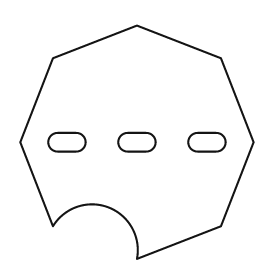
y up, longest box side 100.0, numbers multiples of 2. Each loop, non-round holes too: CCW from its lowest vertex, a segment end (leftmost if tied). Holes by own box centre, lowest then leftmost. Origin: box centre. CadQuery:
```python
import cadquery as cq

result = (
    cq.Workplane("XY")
    .moveTo(0.0, -50.0)
    .lineTo(36.0, -36.0)
    .lineTo(50.0, 0.0)
    .lineTo(36.0, 36.0)
    .lineTo(0.0, 50.0)
    .lineTo(-36.0, 36.0)
    .lineTo(-50.0, 0.0)
    .lineTo(-36.0, -36.0)
    .threePointArc((-12.0, -28.0), (0.0, -50.0))
    .close()
    .moveTo(-34.0, -4.0)
    .lineTo(-26.0, -4.0)
    .threePointArc((-22.0, 0.0), (-26.0, 4.0))
    .lineTo(-34.0, 4.0)
    .threePointArc((-38.0, 0.0), (-34.0, -4.0))
    .close()
    .moveTo(-4.0, -4.0)
    .lineTo(4.0, -4.0)
    .threePointArc((8.0, 0.0), (4.0, 4.0))
    .lineTo(-4.0, 4.0)
    .threePointArc((-8.0, 0.0), (-4.0, -4.0))
    .close()
    .moveTo(26.0, -4.0)
    .lineTo(34.0, -4.0)
    .threePointArc((38.0, 0.0), (34.0, 4.0))
    .lineTo(26.0, 4.0)
    .threePointArc((22.0, 0.0), (26.0, -4.0))
    .close()
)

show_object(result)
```